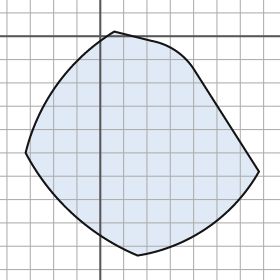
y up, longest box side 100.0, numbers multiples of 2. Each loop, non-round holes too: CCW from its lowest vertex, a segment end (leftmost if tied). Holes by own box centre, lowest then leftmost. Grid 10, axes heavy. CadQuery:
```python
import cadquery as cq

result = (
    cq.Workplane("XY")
    .moveTo(16.0, -94.0)
    .threePointArc((46.0, -82.0), (68.0, -58.0))
    .lineTo(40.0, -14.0)
    .threePointArc((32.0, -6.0), (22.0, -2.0))
    .lineTo(6.0, 2.0)
    .threePointArc((-18.0, -20.0), (-32.0, -50.0))
    .threePointArc((-12.0, -76.0), (16.0, -94.0))
    .close()
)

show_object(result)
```